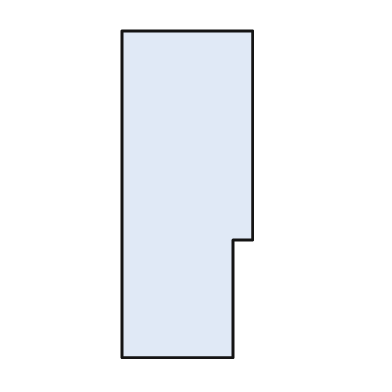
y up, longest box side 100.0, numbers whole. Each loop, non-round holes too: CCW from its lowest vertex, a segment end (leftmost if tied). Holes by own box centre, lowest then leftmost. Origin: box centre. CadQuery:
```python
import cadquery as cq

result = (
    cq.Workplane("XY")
    .moveTo(-20.0, -50.0)
    .lineTo(14.0, -50.0)
    .lineTo(14.0, -14.0)
    .lineTo(20.0, -14.0)
    .lineTo(20.0, 50.0)
    .lineTo(-20.0, 50.0)
    .close()
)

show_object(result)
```